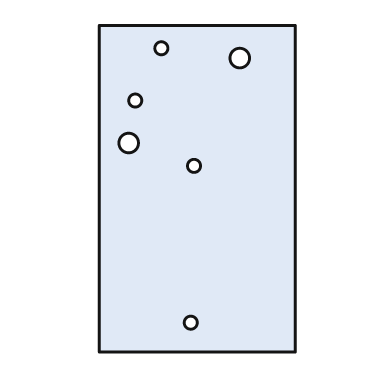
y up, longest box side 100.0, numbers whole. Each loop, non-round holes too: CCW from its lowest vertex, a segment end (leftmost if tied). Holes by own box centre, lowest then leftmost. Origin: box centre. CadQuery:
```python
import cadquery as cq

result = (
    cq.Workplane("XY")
    .moveTo(-30.0, -50.0)
    .lineTo(30.0, -50.0)
    .lineTo(30.0, 50.0)
    .lineTo(-30.0, 50.0)
    .close()
    .moveTo(-2.0, -41.0)
    .circle(2.0)
    .moveTo(-1.0, 7.0)
    .circle(2.0)
    .moveTo(-21.0, 14.0)
    .circle(3.0)
    .moveTo(-19.0, 27.0)
    .circle(2.0)
    .moveTo(13.0, 40.0)
    .circle(3.0)
    .moveTo(-11.0, 43.0)
    .circle(2.0)
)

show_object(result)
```